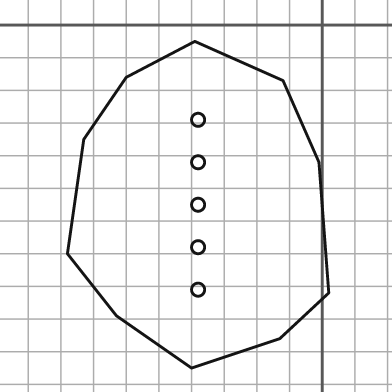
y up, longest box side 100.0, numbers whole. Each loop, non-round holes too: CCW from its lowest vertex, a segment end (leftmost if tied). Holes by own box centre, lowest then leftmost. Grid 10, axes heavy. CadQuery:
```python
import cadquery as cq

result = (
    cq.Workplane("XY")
    .moveTo(-40.0, -105.0)
    .lineTo(-13.0, -96.0)
    .lineTo(2.0, -82.0)
    .lineTo(-1.0, -42.0)
    .lineTo(-12.0, -17.0)
    .lineTo(-39.0, -5.0)
    .lineTo(-60.0, -16.0)
    .lineTo(-73.0, -35.0)
    .lineTo(-78.0, -70.0)
    .lineTo(-63.0, -89.0)
    .close()
    .moveTo(-38.0, -81.0)
    .circle(2.0)
    .moveTo(-38.0, -68.0)
    .circle(2.0)
    .moveTo(-38.0, -55.0)
    .circle(2.0)
    .moveTo(-38.0, -42.0)
    .circle(2.0)
    .moveTo(-38.0, -29.0)
    .circle(2.0)
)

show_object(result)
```